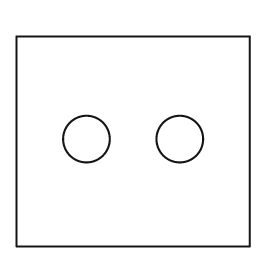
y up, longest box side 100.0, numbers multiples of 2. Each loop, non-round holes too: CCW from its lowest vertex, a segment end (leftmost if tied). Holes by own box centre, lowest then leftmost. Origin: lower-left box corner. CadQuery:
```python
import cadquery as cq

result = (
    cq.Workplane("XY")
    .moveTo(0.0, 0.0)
    .lineTo(100.0, 0.0)
    .lineTo(100.0, 90.0)
    .lineTo(0.0, 90.0)
    .close()
    .moveTo(30.0, 46.0)
    .circle(10.0)
    .moveTo(70.0, 46.0)
    .circle(10.0)
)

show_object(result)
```